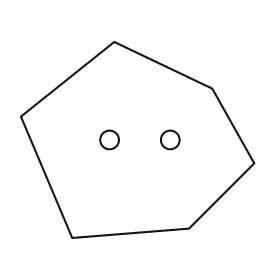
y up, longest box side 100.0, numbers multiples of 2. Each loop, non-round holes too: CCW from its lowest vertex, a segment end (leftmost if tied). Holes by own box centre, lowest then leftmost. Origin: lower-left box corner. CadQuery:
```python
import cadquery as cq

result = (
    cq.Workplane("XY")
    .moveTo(22.0, 0.0)
    .lineTo(72.0, 4.0)
    .lineTo(100.0, 32.0)
    .lineTo(82.0, 64.0)
    .lineTo(40.0, 84.0)
    .lineTo(0.0, 52.0)
    .close()
    .moveTo(38.0, 42.0)
    .circle(4.0)
    .moveTo(64.0, 42.0)
    .circle(4.0)
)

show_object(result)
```